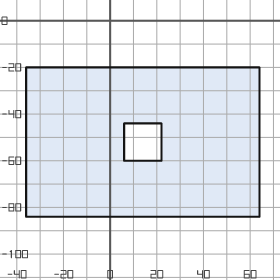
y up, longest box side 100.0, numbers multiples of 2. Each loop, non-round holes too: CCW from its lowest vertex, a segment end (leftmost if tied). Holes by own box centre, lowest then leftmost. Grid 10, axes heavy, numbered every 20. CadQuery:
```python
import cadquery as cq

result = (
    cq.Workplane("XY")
    .moveTo(-36.0, -84.0)
    .lineTo(64.0, -84.0)
    .lineTo(64.0, -20.0)
    .lineTo(-36.0, -20.0)
    .close()
    .moveTo(6.0, -60.0)
    .lineTo(22.0, -60.0)
    .lineTo(22.0, -44.0)
    .lineTo(6.0, -44.0)
    .close()
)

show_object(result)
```